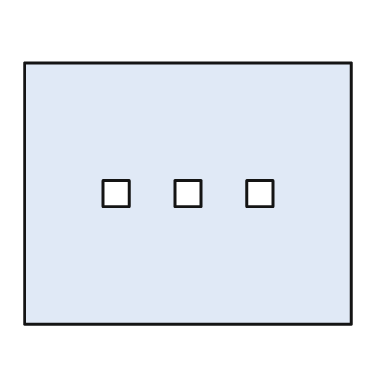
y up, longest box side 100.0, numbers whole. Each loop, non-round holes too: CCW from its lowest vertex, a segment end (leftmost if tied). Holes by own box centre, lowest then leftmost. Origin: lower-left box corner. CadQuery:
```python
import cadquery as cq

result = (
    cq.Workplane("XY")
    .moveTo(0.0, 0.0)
    .lineTo(100.0, 0.0)
    .lineTo(100.0, 80.0)
    .lineTo(0.0, 80.0)
    .close()
    .moveTo(24.0, 36.0)
    .lineTo(32.0, 36.0)
    .lineTo(32.0, 44.0)
    .lineTo(24.0, 44.0)
    .close()
    .moveTo(46.0, 36.0)
    .lineTo(54.0, 36.0)
    .lineTo(54.0, 44.0)
    .lineTo(46.0, 44.0)
    .close()
    .moveTo(68.0, 36.0)
    .lineTo(76.0, 36.0)
    .lineTo(76.0, 44.0)
    .lineTo(68.0, 44.0)
    .close()
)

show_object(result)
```